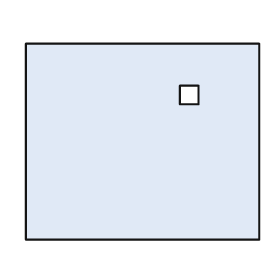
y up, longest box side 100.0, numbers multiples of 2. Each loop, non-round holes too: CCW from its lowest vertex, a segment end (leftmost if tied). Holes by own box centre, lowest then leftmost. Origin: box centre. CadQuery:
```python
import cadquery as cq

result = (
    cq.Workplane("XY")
    .moveTo(-50.0, -42.0)
    .lineTo(50.0, -42.0)
    .lineTo(50.0, 42.0)
    .lineTo(-50.0, 42.0)
    .close()
    .moveTo(16.0, 16.0)
    .lineTo(24.0, 16.0)
    .lineTo(24.0, 24.0)
    .lineTo(16.0, 24.0)
    .close()
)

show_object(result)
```